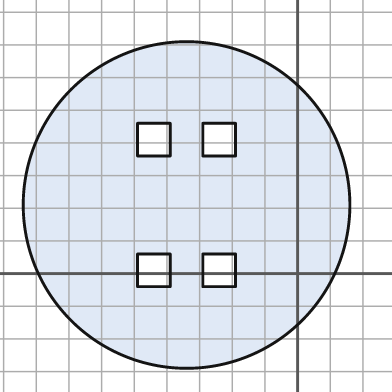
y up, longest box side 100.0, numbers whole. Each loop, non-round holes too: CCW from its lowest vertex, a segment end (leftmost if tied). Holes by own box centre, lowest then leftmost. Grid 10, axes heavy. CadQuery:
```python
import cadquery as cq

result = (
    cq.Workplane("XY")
    .moveTo(-34.0, 21.0)
    .circle(50.0)
    .moveTo(-49.0, -4.0)
    .lineTo(-39.0, -4.0)
    .lineTo(-39.0, 6.0)
    .lineTo(-49.0, 6.0)
    .close()
    .moveTo(-29.0, -4.0)
    .lineTo(-19.0, -4.0)
    .lineTo(-19.0, 6.0)
    .lineTo(-29.0, 6.0)
    .close()
    .moveTo(-49.0, 36.0)
    .lineTo(-39.0, 36.0)
    .lineTo(-39.0, 46.0)
    .lineTo(-49.0, 46.0)
    .close()
    .moveTo(-29.0, 36.0)
    .lineTo(-19.0, 36.0)
    .lineTo(-19.0, 46.0)
    .lineTo(-29.0, 46.0)
    .close()
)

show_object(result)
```